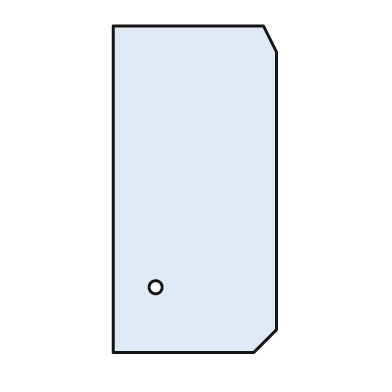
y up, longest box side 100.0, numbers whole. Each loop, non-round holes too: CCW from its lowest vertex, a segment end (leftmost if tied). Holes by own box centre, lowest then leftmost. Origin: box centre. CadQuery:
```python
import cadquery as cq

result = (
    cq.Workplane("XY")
    .moveTo(-25.0, -50.0)
    .lineTo(18.0, -50.0)
    .lineTo(25.0, -43.0)
    .lineTo(25.0, 42.0)
    .lineTo(21.0, 50.0)
    .lineTo(-25.0, 50.0)
    .close()
    .moveTo(-12.0, -30.0)
    .circle(2.0)
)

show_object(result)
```